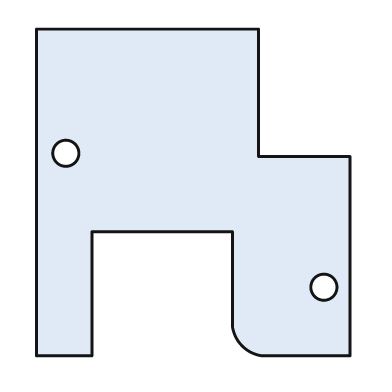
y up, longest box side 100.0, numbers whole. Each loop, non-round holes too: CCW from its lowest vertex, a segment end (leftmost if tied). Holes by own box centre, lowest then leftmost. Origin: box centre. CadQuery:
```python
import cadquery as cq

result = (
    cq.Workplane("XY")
    .moveTo(-48.0, -50.0)
    .lineTo(-31.0, -50.0)
    .lineTo(-31.0, -12.0)
    .lineTo(12.0, -12.0)
    .lineTo(12.0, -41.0)
    .threePointArc((15.0, -47.0), (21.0, -50.0))
    .lineTo(48.0, -50.0)
    .lineTo(48.0, 11.0)
    .lineTo(20.0, 11.0)
    .lineTo(20.0, 50.0)
    .lineTo(-48.0, 50.0)
    .close()
    .moveTo(40.0, -29.0)
    .circle(4.0)
    .moveTo(-39.0, 12.0)
    .circle(4.0)
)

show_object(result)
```